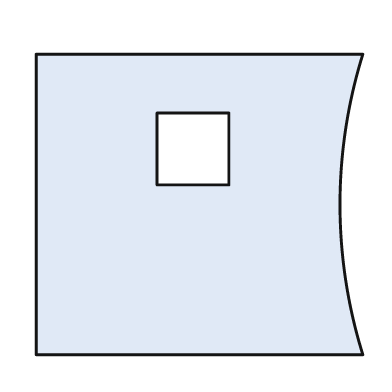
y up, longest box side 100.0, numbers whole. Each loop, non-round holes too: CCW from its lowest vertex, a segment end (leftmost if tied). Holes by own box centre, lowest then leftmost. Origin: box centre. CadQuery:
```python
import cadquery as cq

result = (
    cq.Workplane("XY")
    .moveTo(-50.0, -46.0)
    .lineTo(50.0, -46.0)
    .threePointArc((43.0, 0.0), (50.0, 46.0))
    .lineTo(-50.0, 46.0)
    .close()
    .moveTo(-13.0, 6.0)
    .lineTo(9.0, 6.0)
    .lineTo(9.0, 28.0)
    .lineTo(-13.0, 28.0)
    .close()
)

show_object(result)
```